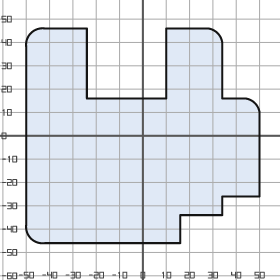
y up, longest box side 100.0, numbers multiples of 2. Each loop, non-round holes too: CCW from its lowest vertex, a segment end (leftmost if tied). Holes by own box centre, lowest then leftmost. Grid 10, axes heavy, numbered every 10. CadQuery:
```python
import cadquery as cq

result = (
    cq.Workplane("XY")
    .moveTo(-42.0, -46.0)
    .lineTo(16.0, -46.0)
    .lineTo(16.0, -34.0)
    .lineTo(34.0, -34.0)
    .lineTo(34.0, -26.0)
    .lineTo(50.0, -26.0)
    .lineTo(50.0, 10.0)
    .threePointArc((48.0, 14.0), (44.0, 16.0))
    .lineTo(34.0, 16.0)
    .lineTo(34.0, 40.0)
    .threePointArc((32.0, 44.0), (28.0, 46.0))
    .lineTo(10.0, 46.0)
    .lineTo(10.0, 16.0)
    .lineTo(-24.0, 16.0)
    .lineTo(-24.0, 46.0)
    .lineTo(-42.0, 46.0)
    .threePointArc((-48.0, 44.0), (-50.0, 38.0))
    .lineTo(-50.0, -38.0)
    .threePointArc((-48.0, -44.0), (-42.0, -46.0))
    .close()
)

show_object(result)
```